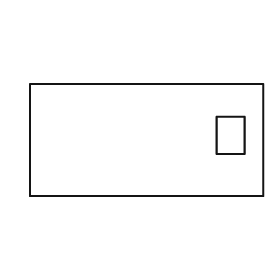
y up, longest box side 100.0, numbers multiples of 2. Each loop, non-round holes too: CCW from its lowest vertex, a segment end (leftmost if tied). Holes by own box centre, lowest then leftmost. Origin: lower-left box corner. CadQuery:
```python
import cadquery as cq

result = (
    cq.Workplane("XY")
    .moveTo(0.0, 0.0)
    .lineTo(100.0, 0.0)
    .lineTo(100.0, 48.0)
    .lineTo(0.0, 48.0)
    .close()
    .moveTo(80.0, 18.0)
    .lineTo(92.0, 18.0)
    .lineTo(92.0, 34.0)
    .lineTo(80.0, 34.0)
    .close()
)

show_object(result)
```